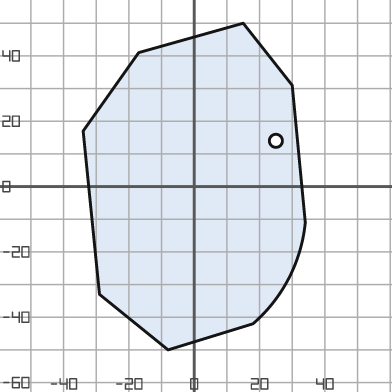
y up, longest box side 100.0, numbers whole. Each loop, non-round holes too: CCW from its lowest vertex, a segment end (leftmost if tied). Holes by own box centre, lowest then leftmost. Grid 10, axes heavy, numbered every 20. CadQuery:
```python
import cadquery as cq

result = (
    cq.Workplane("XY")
    .moveTo(-8.0, -50.0)
    .lineTo(18.0, -42.0)
    .threePointArc((29.0, -28.0), (34.0, -11.0))
    .lineTo(30.0, 31.0)
    .lineTo(15.0, 50.0)
    .lineTo(-17.0, 41.0)
    .lineTo(-34.0, 17.0)
    .lineTo(-29.0, -33.0)
    .close()
    .moveTo(25.0, 14.0)
    .circle(2.0)
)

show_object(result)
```